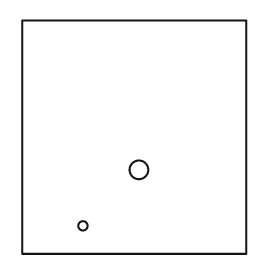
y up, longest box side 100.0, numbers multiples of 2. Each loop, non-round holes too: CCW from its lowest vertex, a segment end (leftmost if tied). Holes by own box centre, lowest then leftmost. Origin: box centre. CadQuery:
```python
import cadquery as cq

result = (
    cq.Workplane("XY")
    .moveTo(-48.0, -50.0)
    .lineTo(48.0, -50.0)
    .lineTo(48.0, 50.0)
    .lineTo(-48.0, 50.0)
    .close()
    .moveTo(-22.0, -38.0)
    .circle(2.0)
    .moveTo(2.0, -14.0)
    .circle(4.0)
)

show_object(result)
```